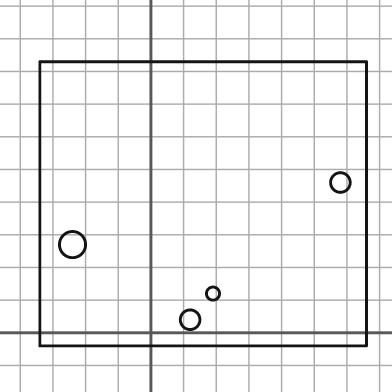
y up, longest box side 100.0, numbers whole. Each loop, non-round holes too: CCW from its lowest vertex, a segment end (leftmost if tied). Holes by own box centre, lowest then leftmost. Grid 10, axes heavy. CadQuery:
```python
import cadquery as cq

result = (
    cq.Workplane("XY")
    .moveTo(-34.0, -4.0)
    .lineTo(66.0, -4.0)
    .lineTo(66.0, 83.0)
    .lineTo(-34.0, 83.0)
    .close()
    .moveTo(12.0, 4.0)
    .circle(3.0)
    .moveTo(19.0, 12.0)
    .circle(2.0)
    .moveTo(-24.0, 27.0)
    .circle(4.0)
    .moveTo(58.0, 46.0)
    .circle(3.0)
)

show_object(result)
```